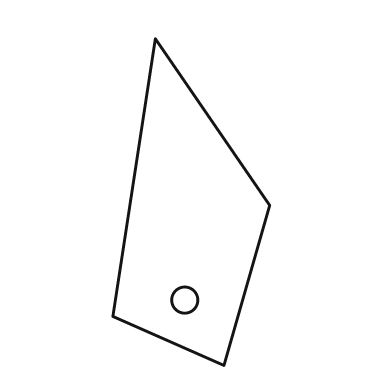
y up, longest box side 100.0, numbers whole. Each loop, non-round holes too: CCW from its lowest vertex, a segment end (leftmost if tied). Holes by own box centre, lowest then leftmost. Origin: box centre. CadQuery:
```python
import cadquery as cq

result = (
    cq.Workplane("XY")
    .moveTo(10.0, -50.0)
    .lineTo(24.0, -1.0)
    .lineTo(-11.0, 50.0)
    .lineTo(-24.0, -35.0)
    .close()
    .moveTo(-2.0, -30.0)
    .circle(4.0)
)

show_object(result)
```